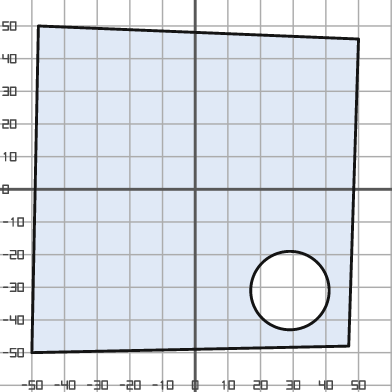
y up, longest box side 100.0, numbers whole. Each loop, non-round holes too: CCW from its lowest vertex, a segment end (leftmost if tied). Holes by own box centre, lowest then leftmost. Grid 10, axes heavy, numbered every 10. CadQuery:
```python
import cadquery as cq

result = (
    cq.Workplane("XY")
    .moveTo(-50.0, -50.0)
    .lineTo(47.0, -48.0)
    .lineTo(50.0, 46.0)
    .lineTo(-48.0, 50.0)
    .close()
    .moveTo(29.0, -31.0)
    .circle(12.0)
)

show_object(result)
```